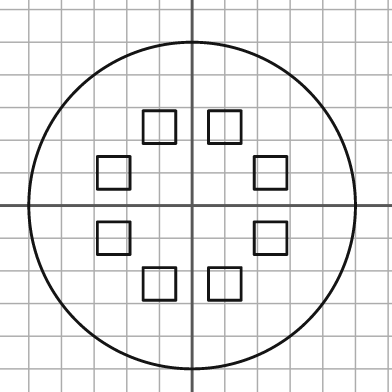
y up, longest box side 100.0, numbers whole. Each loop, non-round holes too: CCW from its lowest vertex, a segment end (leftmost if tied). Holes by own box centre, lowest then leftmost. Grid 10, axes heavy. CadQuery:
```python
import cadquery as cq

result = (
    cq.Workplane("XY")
    .moveTo(0.0, 0.0)
    .circle(50.0)
    .moveTo(-15.0, -29.0)
    .lineTo(-5.0, -29.0)
    .lineTo(-5.0, -19.0)
    .lineTo(-15.0, -19.0)
    .close()
    .moveTo(5.0, -29.0)
    .lineTo(15.0, -29.0)
    .lineTo(15.0, -19.0)
    .lineTo(5.0, -19.0)
    .close()
    .moveTo(-29.0, -15.0)
    .lineTo(-19.0, -15.0)
    .lineTo(-19.0, -5.0)
    .lineTo(-29.0, -5.0)
    .close()
    .moveTo(19.0, -15.0)
    .lineTo(29.0, -15.0)
    .lineTo(29.0, -5.0)
    .lineTo(19.0, -5.0)
    .close()
    .moveTo(-29.0, 5.0)
    .lineTo(-19.0, 5.0)
    .lineTo(-19.0, 15.0)
    .lineTo(-29.0, 15.0)
    .close()
    .moveTo(19.0, 5.0)
    .lineTo(29.0, 5.0)
    .lineTo(29.0, 15.0)
    .lineTo(19.0, 15.0)
    .close()
    .moveTo(-15.0, 19.0)
    .lineTo(-5.0, 19.0)
    .lineTo(-5.0, 29.0)
    .lineTo(-15.0, 29.0)
    .close()
    .moveTo(5.0, 19.0)
    .lineTo(15.0, 19.0)
    .lineTo(15.0, 29.0)
    .lineTo(5.0, 29.0)
    .close()
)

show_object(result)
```